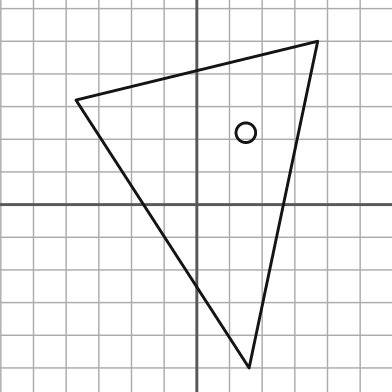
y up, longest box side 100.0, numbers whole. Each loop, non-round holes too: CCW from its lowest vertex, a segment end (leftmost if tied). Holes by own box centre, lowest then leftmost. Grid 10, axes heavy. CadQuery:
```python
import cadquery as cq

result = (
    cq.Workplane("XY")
    .moveTo(16.0, -50.0)
    .lineTo(37.0, 50.0)
    .lineTo(-37.0, 32.0)
    .close()
    .moveTo(15.0, 22.0)
    .circle(3.0)
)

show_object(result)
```